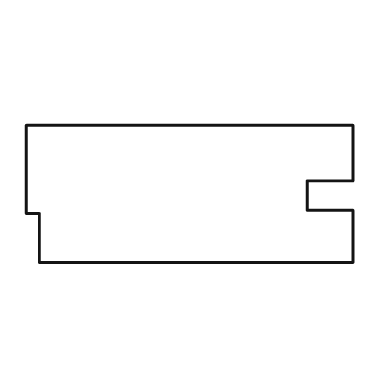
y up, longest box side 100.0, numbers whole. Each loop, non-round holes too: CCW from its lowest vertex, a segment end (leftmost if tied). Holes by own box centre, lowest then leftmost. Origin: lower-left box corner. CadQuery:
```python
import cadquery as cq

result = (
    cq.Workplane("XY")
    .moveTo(4.0, 0.0)
    .lineTo(100.0, 0.0)
    .lineTo(100.0, 16.0)
    .lineTo(86.0, 16.0)
    .lineTo(86.0, 25.0)
    .lineTo(100.0, 25.0)
    .lineTo(100.0, 42.0)
    .lineTo(0.0, 42.0)
    .lineTo(0.0, 15.0)
    .lineTo(4.0, 15.0)
    .close()
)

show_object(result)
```